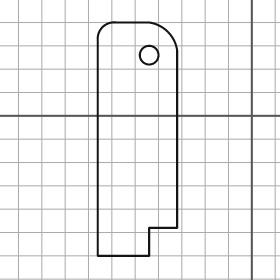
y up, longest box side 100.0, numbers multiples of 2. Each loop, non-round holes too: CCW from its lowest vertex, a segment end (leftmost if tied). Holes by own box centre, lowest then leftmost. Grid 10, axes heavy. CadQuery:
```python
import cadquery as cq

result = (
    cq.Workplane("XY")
    .moveTo(-66.0, -60.0)
    .lineTo(-44.0, -60.0)
    .lineTo(-44.0, -48.0)
    .lineTo(-32.0, -48.0)
    .lineTo(-32.0, 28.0)
    .threePointArc((-36.0, 36.0), (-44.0, 40.0))
    .lineTo(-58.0, 40.0)
    .threePointArc((-64.0, 38.0), (-66.0, 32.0))
    .close()
    .moveTo(-44.0, 26.0)
    .circle(4.0)
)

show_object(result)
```